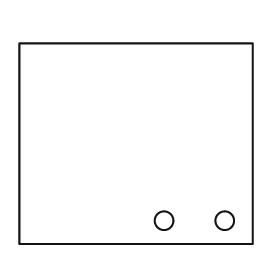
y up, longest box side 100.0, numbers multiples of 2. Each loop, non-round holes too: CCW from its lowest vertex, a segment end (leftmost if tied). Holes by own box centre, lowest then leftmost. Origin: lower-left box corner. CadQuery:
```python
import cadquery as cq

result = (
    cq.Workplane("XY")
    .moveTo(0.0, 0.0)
    .lineTo(100.0, 0.0)
    .lineTo(100.0, 86.0)
    .lineTo(0.0, 86.0)
    .close()
    .moveTo(62.0, 10.0)
    .circle(4.0)
    .moveTo(88.0, 10.0)
    .circle(4.0)
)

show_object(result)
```